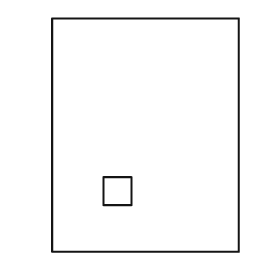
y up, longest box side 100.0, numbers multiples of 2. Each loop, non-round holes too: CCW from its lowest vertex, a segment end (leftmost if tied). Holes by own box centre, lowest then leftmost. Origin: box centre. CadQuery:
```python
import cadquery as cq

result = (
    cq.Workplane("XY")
    .moveTo(-40.0, -50.0)
    .lineTo(40.0, -50.0)
    .lineTo(40.0, 50.0)
    .lineTo(-40.0, 50.0)
    .close()
    .moveTo(-18.0, -30.0)
    .lineTo(-6.0, -30.0)
    .lineTo(-6.0, -18.0)
    .lineTo(-18.0, -18.0)
    .close()
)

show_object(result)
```